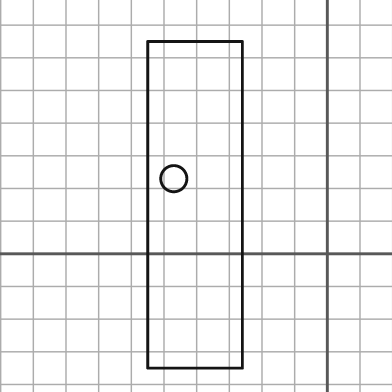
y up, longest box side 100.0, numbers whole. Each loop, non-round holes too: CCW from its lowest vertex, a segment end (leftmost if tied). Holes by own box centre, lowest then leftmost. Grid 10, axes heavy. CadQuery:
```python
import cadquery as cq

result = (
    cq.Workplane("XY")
    .moveTo(-55.0, -35.0)
    .lineTo(-26.0, -35.0)
    .lineTo(-26.0, 65.0)
    .lineTo(-55.0, 65.0)
    .close()
    .moveTo(-47.0, 23.0)
    .circle(4.0)
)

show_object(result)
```